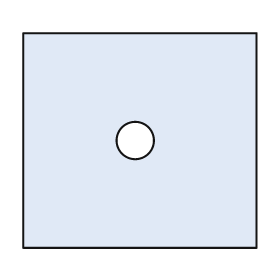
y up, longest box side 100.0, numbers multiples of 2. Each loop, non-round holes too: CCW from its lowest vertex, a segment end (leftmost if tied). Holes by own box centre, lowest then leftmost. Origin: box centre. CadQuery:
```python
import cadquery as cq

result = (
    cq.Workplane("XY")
    .moveTo(-50.0, -46.0)
    .lineTo(50.0, -46.0)
    .lineTo(50.0, 46.0)
    .lineTo(-50.0, 46.0)
    .close()
    .moveTo(-2.0, 0.0)
    .circle(8.0)
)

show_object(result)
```